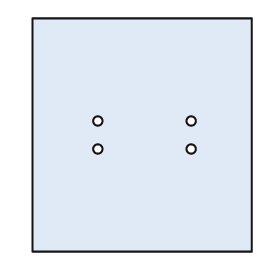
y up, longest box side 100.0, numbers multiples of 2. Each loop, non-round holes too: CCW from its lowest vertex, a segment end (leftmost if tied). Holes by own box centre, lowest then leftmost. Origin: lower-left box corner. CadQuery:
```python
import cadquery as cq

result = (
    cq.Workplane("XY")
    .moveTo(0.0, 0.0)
    .lineTo(94.0, 0.0)
    .lineTo(94.0, 100.0)
    .lineTo(0.0, 100.0)
    .close()
    .moveTo(28.0, 44.0)
    .circle(2.0)
    .moveTo(68.0, 44.0)
    .circle(2.0)
    .moveTo(28.0, 56.0)
    .circle(2.0)
    .moveTo(68.0, 56.0)
    .circle(2.0)
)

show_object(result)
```